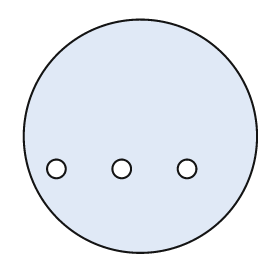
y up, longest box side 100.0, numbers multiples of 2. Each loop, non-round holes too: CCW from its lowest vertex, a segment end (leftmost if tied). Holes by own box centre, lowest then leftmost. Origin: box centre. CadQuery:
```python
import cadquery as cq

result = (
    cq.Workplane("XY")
    .moveTo(0.0, 0.0)
    .circle(50.0)
    .moveTo(-36.0, -14.0)
    .circle(4.0)
    .moveTo(-8.0, -14.0)
    .circle(4.0)
    .moveTo(20.0, -14.0)
    .circle(4.0)
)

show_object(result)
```